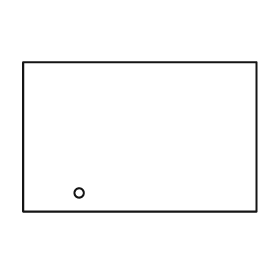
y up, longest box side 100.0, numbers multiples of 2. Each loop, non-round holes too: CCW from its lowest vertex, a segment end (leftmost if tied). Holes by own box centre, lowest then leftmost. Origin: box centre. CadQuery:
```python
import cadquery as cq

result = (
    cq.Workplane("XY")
    .moveTo(-50.0, -32.0)
    .lineTo(50.0, -32.0)
    .lineTo(50.0, 32.0)
    .lineTo(-50.0, 32.0)
    .close()
    .moveTo(-26.0, -24.0)
    .circle(2.0)
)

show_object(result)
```